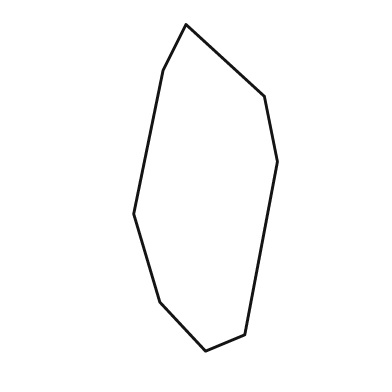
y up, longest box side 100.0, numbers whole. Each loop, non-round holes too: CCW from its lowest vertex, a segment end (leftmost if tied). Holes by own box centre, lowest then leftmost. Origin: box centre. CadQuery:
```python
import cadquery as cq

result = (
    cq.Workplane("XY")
    .moveTo(0.0, -50.0)
    .lineTo(12.0, -45.0)
    .lineTo(22.0, 8.0)
    .lineTo(18.0, 28.0)
    .lineTo(-6.0, 50.0)
    .lineTo(-13.0, 36.0)
    .lineTo(-22.0, -8.0)
    .lineTo(-14.0, -35.0)
    .close()
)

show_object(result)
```